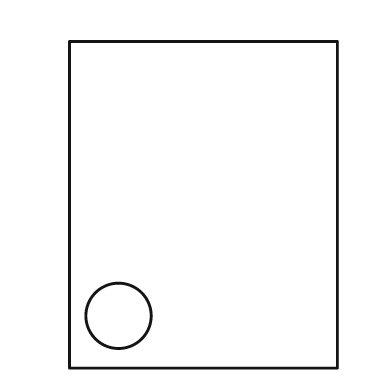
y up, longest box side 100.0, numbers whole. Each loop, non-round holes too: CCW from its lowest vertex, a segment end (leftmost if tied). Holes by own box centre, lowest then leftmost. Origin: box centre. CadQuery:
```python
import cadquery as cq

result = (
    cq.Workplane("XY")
    .moveTo(-41.0, -50.0)
    .lineTo(41.0, -50.0)
    .lineTo(41.0, 50.0)
    .lineTo(-41.0, 50.0)
    .close()
    .moveTo(-26.0, -34.0)
    .circle(10.0)
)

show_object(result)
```